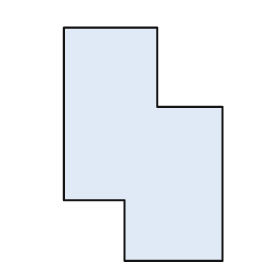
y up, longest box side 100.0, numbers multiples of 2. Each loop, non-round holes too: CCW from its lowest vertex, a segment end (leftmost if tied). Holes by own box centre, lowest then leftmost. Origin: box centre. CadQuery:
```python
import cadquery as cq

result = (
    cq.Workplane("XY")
    .moveTo(-8.0, -50.0)
    .lineTo(34.0, -50.0)
    .lineTo(34.0, 16.0)
    .lineTo(6.0, 16.0)
    .lineTo(6.0, 50.0)
    .lineTo(-34.0, 50.0)
    .lineTo(-34.0, -24.0)
    .lineTo(-8.0, -24.0)
    .close()
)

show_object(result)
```